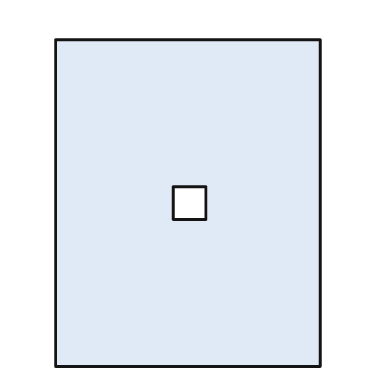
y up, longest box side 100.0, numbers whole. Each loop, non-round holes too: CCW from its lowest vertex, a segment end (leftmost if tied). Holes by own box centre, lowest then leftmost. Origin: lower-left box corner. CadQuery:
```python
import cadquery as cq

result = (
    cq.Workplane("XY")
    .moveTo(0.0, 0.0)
    .lineTo(81.0, 0.0)
    .lineTo(81.0, 100.0)
    .lineTo(0.0, 100.0)
    .close()
    .moveTo(36.0, 45.0)
    .lineTo(46.0, 45.0)
    .lineTo(46.0, 55.0)
    .lineTo(36.0, 55.0)
    .close()
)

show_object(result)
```